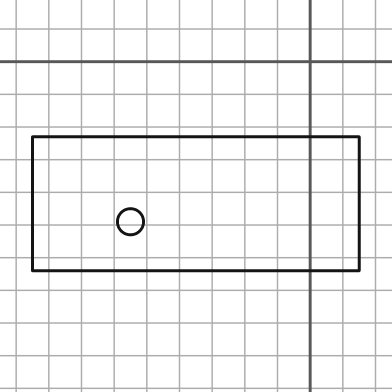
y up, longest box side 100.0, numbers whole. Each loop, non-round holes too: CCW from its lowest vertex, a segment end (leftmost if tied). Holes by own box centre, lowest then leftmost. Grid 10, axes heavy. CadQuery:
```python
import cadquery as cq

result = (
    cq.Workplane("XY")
    .moveTo(-85.0, -64.0)
    .lineTo(15.0, -64.0)
    .lineTo(15.0, -23.0)
    .lineTo(-85.0, -23.0)
    .close()
    .moveTo(-55.0, -49.0)
    .circle(4.0)
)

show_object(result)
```